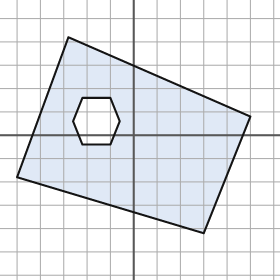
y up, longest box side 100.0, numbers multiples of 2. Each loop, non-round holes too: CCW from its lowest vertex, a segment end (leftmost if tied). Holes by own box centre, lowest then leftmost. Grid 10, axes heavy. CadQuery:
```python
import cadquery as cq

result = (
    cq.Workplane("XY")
    .moveTo(30.0, -42.0)
    .lineTo(50.0, 8.0)
    .lineTo(-28.0, 42.0)
    .lineTo(-50.0, -18.0)
    .close()
    .moveTo(-22.0, -4.0)
    .lineTo(-10.0, -4.0)
    .lineTo(-6.0, 6.0)
    .lineTo(-10.0, 16.0)
    .lineTo(-22.0, 16.0)
    .lineTo(-26.0, 6.0)
    .close()
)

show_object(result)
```